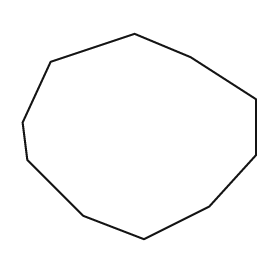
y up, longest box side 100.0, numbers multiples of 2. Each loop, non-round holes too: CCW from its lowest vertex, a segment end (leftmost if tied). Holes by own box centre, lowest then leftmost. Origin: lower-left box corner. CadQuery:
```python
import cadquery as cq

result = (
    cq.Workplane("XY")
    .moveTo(52.0, 0.0)
    .lineTo(80.0, 14.0)
    .lineTo(100.0, 36.0)
    .lineTo(100.0, 60.0)
    .lineTo(72.0, 78.0)
    .lineTo(48.0, 88.0)
    .lineTo(12.0, 76.0)
    .lineTo(0.0, 50.0)
    .lineTo(2.0, 34.0)
    .lineTo(26.0, 10.0)
    .close()
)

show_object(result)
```